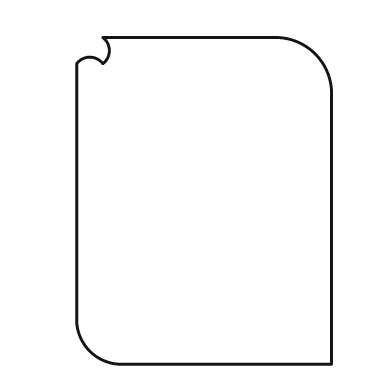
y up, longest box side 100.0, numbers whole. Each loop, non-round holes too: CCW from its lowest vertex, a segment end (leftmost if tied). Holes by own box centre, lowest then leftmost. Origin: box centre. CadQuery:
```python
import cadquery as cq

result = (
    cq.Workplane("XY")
    .moveTo(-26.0, -50.0)
    .lineTo(39.0, -50.0)
    .lineTo(39.0, 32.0)
    .threePointArc((34.0, 45.0), (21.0, 50.0))
    .lineTo(-31.0, 50.0)
    .threePointArc((-29.0, 46.0), (-31.0, 42.0))
    .threePointArc((-35.0, 44.0), (-39.0, 42.0))
    .lineTo(-39.0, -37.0)
    .threePointArc((-35.0, -46.0), (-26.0, -50.0))
    .close()
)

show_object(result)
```